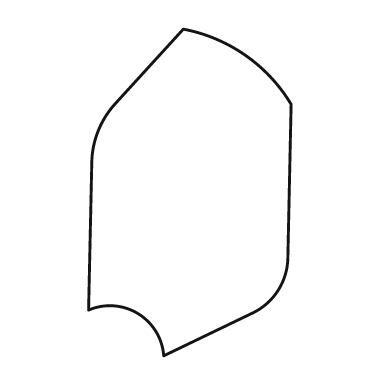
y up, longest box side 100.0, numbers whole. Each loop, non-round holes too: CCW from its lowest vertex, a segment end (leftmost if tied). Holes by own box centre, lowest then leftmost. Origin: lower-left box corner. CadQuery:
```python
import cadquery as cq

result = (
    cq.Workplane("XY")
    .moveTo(23.0, 0.0)
    .lineTo(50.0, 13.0)
    .threePointArc((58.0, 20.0), (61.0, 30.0))
    .lineTo(62.0, 77.0)
    .threePointArc((48.0, 92.0), (29.0, 100.0))
    .lineTo(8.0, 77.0)
    .threePointArc((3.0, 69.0), (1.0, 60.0))
    .lineTo(0.0, 14.0)
    .threePointArc((15.0, 13.0), (23.0, 0.0))
    .close()
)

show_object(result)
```